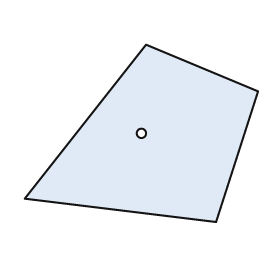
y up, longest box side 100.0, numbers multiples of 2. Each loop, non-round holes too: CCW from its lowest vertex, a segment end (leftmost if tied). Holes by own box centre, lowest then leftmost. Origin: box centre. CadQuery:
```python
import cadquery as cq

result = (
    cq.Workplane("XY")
    .moveTo(32.0, -38.0)
    .lineTo(50.0, 18.0)
    .lineTo(2.0, 38.0)
    .lineTo(-50.0, -28.0)
    .close()
    .moveTo(0.0, 0.0)
    .circle(2.0)
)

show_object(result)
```